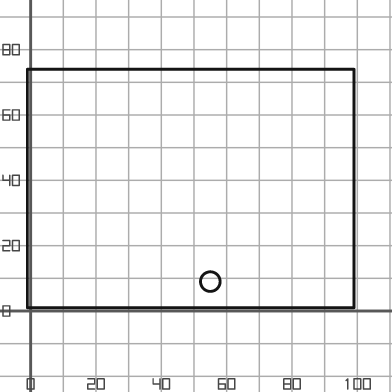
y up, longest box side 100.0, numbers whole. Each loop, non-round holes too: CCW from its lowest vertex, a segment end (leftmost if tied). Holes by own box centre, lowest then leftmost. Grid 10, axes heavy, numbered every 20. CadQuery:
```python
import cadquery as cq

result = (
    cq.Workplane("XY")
    .moveTo(-1.0, 1.0)
    .lineTo(99.0, 1.0)
    .lineTo(99.0, 74.0)
    .lineTo(-1.0, 74.0)
    .close()
    .moveTo(55.0, 9.0)
    .circle(3.0)
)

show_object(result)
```